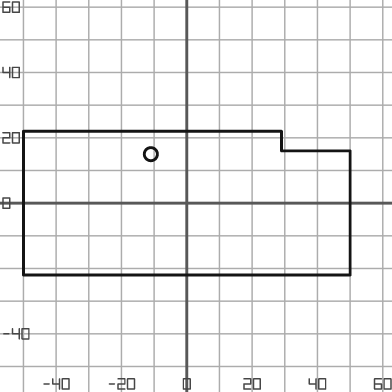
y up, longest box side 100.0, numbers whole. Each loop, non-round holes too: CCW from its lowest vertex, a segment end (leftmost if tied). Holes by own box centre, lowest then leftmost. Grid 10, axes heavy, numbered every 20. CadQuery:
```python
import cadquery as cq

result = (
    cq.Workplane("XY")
    .moveTo(-50.0, -22.0)
    .lineTo(50.0, -22.0)
    .lineTo(50.0, 16.0)
    .lineTo(29.0, 16.0)
    .lineTo(29.0, 22.0)
    .lineTo(-50.0, 22.0)
    .close()
    .moveTo(-11.0, 15.0)
    .circle(2.0)
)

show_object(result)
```